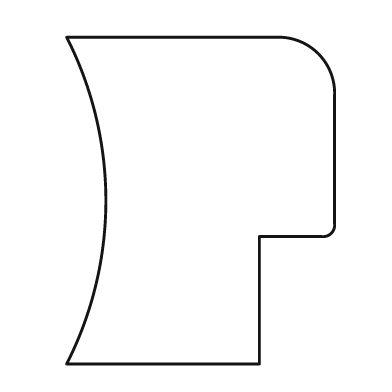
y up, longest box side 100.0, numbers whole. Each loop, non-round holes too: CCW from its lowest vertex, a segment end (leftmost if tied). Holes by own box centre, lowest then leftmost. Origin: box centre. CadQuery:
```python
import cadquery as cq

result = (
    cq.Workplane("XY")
    .moveTo(-41.0, -50.0)
    .lineTo(18.0, -50.0)
    .lineTo(18.0, -11.0)
    .lineTo(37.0, -11.0)
    .threePointArc((40.0, -10.0), (41.0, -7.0))
    .lineTo(41.0, 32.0)
    .threePointArc((36.0, 45.0), (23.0, 50.0))
    .lineTo(-41.0, 50.0)
    .threePointArc((-29.0, 0.0), (-41.0, -50.0))
    .close()
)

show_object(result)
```